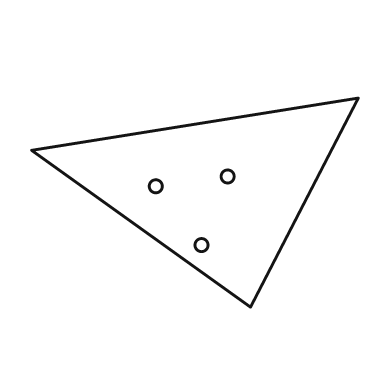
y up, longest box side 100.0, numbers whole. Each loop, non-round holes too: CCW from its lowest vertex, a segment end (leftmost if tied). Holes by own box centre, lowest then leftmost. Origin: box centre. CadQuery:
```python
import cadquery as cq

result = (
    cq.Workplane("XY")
    .moveTo(17.0, -32.0)
    .lineTo(50.0, 32.0)
    .lineTo(-50.0, 16.0)
    .close()
    .moveTo(2.0, -13.0)
    .circle(2.0)
    .moveTo(-12.0, 5.0)
    .circle(2.0)
    .moveTo(10.0, 8.0)
    .circle(2.0)
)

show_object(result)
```